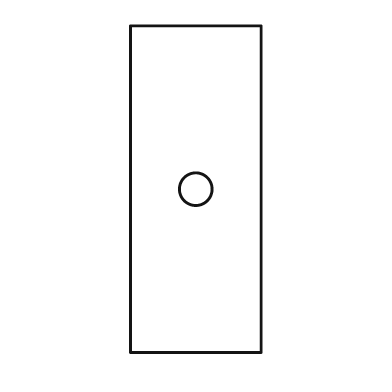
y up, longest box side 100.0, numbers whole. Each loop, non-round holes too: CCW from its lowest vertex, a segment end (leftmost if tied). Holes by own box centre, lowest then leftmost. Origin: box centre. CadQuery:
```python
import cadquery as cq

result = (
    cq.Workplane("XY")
    .moveTo(-20.0, -50.0)
    .lineTo(20.0, -50.0)
    .lineTo(20.0, 50.0)
    .lineTo(-20.0, 50.0)
    .close()
    .moveTo(0.0, 0.0)
    .circle(5.0)
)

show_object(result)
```